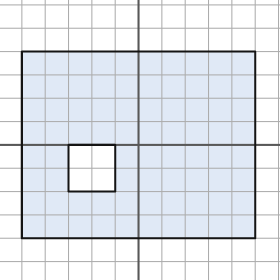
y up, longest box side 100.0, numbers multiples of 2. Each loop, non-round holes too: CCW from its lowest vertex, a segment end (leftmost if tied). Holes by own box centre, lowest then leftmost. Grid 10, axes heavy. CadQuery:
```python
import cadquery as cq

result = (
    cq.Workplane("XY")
    .moveTo(-50.0, -40.0)
    .lineTo(50.0, -40.0)
    .lineTo(50.0, 40.0)
    .lineTo(-50.0, 40.0)
    .close()
    .moveTo(-30.0, -20.0)
    .lineTo(-10.0, -20.0)
    .lineTo(-10.0, 0.0)
    .lineTo(-30.0, 0.0)
    .close()
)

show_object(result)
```